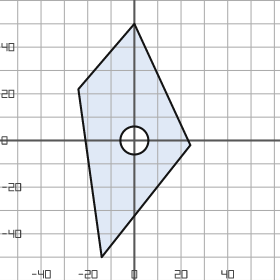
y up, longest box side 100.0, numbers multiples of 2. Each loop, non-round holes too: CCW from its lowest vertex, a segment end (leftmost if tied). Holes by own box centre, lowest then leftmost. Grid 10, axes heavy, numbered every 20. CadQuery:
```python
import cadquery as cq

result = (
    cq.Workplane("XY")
    .moveTo(-14.0, -50.0)
    .lineTo(24.0, -2.0)
    .lineTo(0.0, 50.0)
    .lineTo(-24.0, 22.0)
    .close()
    .moveTo(0.0, 0.0)
    .circle(6.0)
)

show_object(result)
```